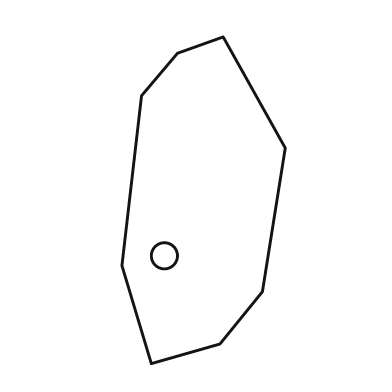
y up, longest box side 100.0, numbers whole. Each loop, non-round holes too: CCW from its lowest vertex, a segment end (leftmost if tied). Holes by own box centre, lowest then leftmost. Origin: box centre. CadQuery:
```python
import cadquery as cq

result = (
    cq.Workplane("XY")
    .moveTo(-16.0, -50.0)
    .lineTo(5.0, -44.0)
    .lineTo(18.0, -28.0)
    .lineTo(25.0, 16.0)
    .lineTo(6.0, 50.0)
    .lineTo(-8.0, 45.0)
    .lineTo(-19.0, 32.0)
    .lineTo(-25.0, -20.0)
    .close()
    .moveTo(-12.0, -17.0)
    .circle(4.0)
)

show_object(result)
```